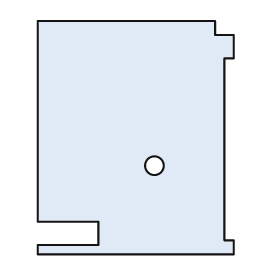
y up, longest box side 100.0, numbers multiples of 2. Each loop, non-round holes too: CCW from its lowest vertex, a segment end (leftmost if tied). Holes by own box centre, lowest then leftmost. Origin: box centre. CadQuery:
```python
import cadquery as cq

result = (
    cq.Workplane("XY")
    .moveTo(-42.0, -50.0)
    .lineTo(42.0, -50.0)
    .lineTo(42.0, -44.0)
    .lineTo(38.0, -44.0)
    .lineTo(38.0, 34.0)
    .lineTo(42.0, 34.0)
    .lineTo(42.0, 44.0)
    .lineTo(34.0, 44.0)
    .lineTo(34.0, 50.0)
    .lineTo(-42.0, 50.0)
    .lineTo(-42.0, -36.0)
    .lineTo(-16.0, -36.0)
    .lineTo(-16.0, -46.0)
    .lineTo(-42.0, -46.0)
    .close()
    .moveTo(8.0, -12.0)
    .circle(4.0)
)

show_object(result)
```